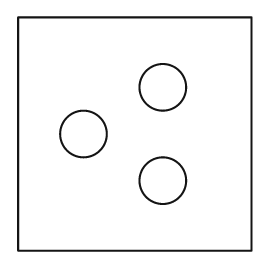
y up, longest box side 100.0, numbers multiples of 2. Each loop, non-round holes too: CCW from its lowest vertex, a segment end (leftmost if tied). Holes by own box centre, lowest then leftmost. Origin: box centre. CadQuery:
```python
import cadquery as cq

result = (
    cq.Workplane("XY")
    .moveTo(-50.0, -50.0)
    .lineTo(50.0, -50.0)
    .lineTo(50.0, 50.0)
    .lineTo(-50.0, 50.0)
    .close()
    .moveTo(12.0, -20.0)
    .circle(10.0)
    .moveTo(-22.0, 0.0)
    .circle(10.0)
    .moveTo(12.0, 20.0)
    .circle(10.0)
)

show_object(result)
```